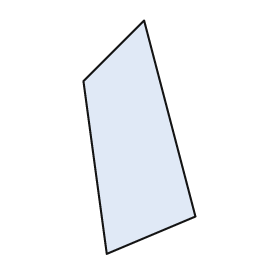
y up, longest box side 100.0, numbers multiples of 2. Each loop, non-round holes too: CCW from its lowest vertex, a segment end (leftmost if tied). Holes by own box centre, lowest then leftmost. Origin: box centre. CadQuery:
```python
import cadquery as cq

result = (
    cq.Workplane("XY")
    .moveTo(-14.0, -50.0)
    .lineTo(24.0, -34.0)
    .lineTo(2.0, 50.0)
    .lineTo(-24.0, 24.0)
    .close()
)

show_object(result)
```